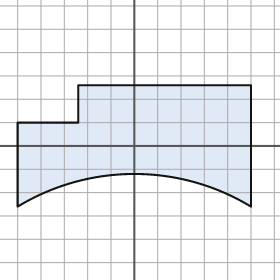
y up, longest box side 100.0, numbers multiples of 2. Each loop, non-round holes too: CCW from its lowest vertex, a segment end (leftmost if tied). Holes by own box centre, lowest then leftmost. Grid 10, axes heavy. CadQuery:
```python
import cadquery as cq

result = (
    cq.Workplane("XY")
    .moveTo(-50.0, -26.0)
    .threePointArc((0.0, -12.0), (50.0, -26.0))
    .lineTo(50.0, 26.0)
    .lineTo(-24.0, 26.0)
    .lineTo(-24.0, 10.0)
    .lineTo(-50.0, 10.0)
    .close()
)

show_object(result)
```